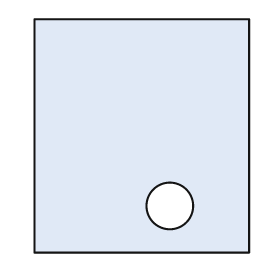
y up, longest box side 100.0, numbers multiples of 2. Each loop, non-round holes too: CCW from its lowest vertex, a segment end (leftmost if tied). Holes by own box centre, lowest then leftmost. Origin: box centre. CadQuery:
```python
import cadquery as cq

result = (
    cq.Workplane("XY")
    .moveTo(-46.0, -50.0)
    .lineTo(46.0, -50.0)
    .lineTo(46.0, 50.0)
    .lineTo(-46.0, 50.0)
    .close()
    .moveTo(12.0, -30.0)
    .circle(10.0)
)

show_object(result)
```